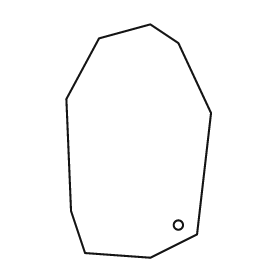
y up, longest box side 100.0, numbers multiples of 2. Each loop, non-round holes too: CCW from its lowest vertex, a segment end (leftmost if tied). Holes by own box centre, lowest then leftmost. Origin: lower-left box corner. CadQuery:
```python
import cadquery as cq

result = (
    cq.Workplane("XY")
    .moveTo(36.0, 0.0)
    .lineTo(56.0, 10.0)
    .lineTo(62.0, 62.0)
    .lineTo(48.0, 92.0)
    .lineTo(36.0, 100.0)
    .lineTo(14.0, 94.0)
    .lineTo(0.0, 68.0)
    .lineTo(2.0, 20.0)
    .lineTo(8.0, 2.0)
    .close()
    .moveTo(48.0, 14.0)
    .circle(2.0)
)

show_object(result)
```